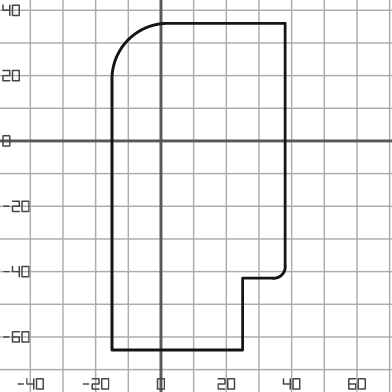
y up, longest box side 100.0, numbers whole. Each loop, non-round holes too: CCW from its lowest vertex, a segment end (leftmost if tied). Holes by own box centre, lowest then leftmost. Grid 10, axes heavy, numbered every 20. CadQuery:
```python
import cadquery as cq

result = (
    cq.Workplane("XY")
    .moveTo(-15.0, -64.0)
    .lineTo(25.0, -64.0)
    .lineTo(25.0, -42.0)
    .lineTo(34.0, -42.0)
    .threePointArc((37.0, -41.0), (38.0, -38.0))
    .lineTo(38.0, 36.0)
    .lineTo(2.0, 36.0)
    .threePointArc((-10.0, 31.0), (-15.0, 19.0))
    .close()
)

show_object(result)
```